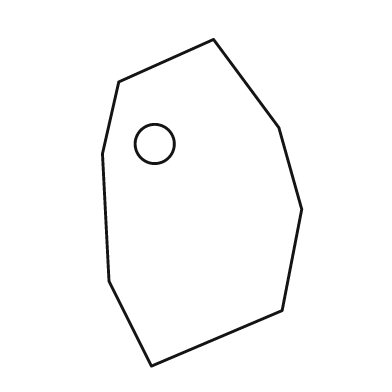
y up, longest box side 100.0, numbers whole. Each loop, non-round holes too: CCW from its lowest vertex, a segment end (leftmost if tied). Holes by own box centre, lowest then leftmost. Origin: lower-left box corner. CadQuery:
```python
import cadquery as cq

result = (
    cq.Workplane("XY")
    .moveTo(15.0, 0.0)
    .lineTo(55.0, 17.0)
    .lineTo(61.0, 48.0)
    .lineTo(54.0, 73.0)
    .lineTo(34.0, 100.0)
    .lineTo(5.0, 87.0)
    .lineTo(0.0, 65.0)
    .lineTo(2.0, 26.0)
    .close()
    .moveTo(16.0, 68.0)
    .circle(6.0)
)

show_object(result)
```